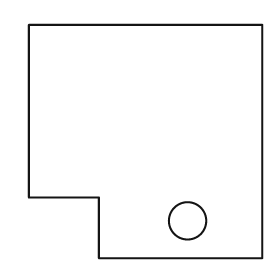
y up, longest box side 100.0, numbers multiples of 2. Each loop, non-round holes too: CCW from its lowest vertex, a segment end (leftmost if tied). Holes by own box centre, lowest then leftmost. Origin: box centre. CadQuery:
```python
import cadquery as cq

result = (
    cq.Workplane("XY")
    .moveTo(-20.0, -50.0)
    .lineTo(50.0, -50.0)
    .lineTo(50.0, 50.0)
    .lineTo(-50.0, 50.0)
    .lineTo(-50.0, -24.0)
    .lineTo(-20.0, -24.0)
    .close()
    .moveTo(18.0, -34.0)
    .circle(8.0)
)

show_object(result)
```